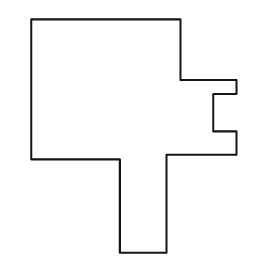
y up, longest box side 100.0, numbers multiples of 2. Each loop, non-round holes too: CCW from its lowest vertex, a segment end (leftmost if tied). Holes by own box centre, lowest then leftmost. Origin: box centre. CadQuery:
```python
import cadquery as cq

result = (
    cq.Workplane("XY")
    .moveTo(-6.0, -50.0)
    .lineTo(14.0, -50.0)
    .lineTo(14.0, -8.0)
    .lineTo(44.0, -8.0)
    .lineTo(44.0, 2.0)
    .lineTo(34.0, 2.0)
    .lineTo(34.0, 18.0)
    .lineTo(44.0, 18.0)
    .lineTo(44.0, 24.0)
    .lineTo(20.0, 24.0)
    .lineTo(20.0, 50.0)
    .lineTo(-44.0, 50.0)
    .lineTo(-44.0, -10.0)
    .lineTo(-6.0, -10.0)
    .close()
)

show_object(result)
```